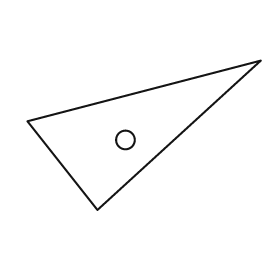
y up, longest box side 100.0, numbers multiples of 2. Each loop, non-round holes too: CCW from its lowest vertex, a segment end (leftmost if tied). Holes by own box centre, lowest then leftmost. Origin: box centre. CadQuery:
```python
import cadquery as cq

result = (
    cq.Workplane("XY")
    .moveTo(-20.0, -32.0)
    .lineTo(50.0, 32.0)
    .lineTo(-50.0, 6.0)
    .close()
    .moveTo(-8.0, -2.0)
    .circle(4.0)
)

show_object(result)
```